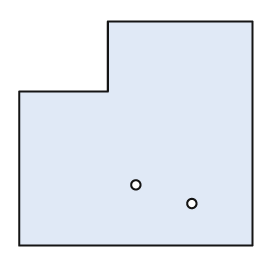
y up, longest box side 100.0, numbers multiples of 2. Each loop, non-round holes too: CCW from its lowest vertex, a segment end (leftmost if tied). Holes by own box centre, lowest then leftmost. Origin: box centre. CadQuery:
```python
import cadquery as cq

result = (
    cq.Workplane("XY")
    .moveTo(-50.0, -48.0)
    .lineTo(50.0, -48.0)
    .lineTo(50.0, 48.0)
    .lineTo(-12.0, 48.0)
    .lineTo(-12.0, 18.0)
    .lineTo(-50.0, 18.0)
    .close()
    .moveTo(24.0, -30.0)
    .circle(2.0)
    .moveTo(0.0, -22.0)
    .circle(2.0)
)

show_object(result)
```